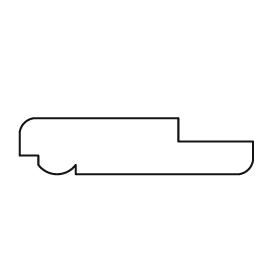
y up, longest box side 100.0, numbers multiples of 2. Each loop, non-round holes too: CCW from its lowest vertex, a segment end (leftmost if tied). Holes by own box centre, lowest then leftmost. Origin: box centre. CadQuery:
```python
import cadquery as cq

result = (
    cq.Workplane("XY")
    .moveTo(-26.0, -12.0)
    .lineTo(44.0, -12.0)
    .threePointArc((48.0, -10.0), (50.0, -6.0))
    .lineTo(50.0, 2.0)
    .lineTo(18.0, 2.0)
    .lineTo(18.0, 12.0)
    .lineTo(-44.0, 12.0)
    .threePointArc((-48.0, 10.0), (-50.0, 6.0))
    .lineTo(-50.0, -4.0)
    .lineTo(-42.0, -4.0)
    .lineTo(-42.0, -8.0)
    .threePointArc((-34.0, -12.0), (-26.0, -8.0))
    .close()
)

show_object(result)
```